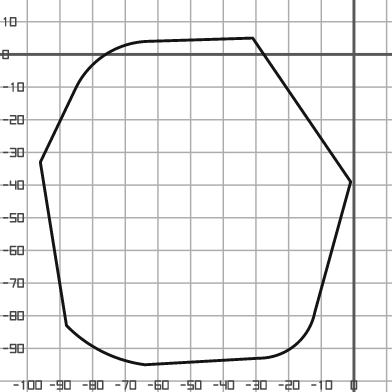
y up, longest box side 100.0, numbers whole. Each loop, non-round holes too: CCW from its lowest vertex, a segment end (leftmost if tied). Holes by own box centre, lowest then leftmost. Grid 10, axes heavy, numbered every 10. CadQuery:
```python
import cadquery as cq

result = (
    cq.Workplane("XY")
    .moveTo(-64.0, -95.0)
    .lineTo(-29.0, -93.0)
    .threePointArc((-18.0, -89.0), (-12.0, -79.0))
    .lineTo(-1.0, -39.0)
    .lineTo(-31.0, 5.0)
    .lineTo(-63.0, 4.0)
    .threePointArc((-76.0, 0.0), (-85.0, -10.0))
    .lineTo(-96.0, -33.0)
    .lineTo(-88.0, -83.0)
    .threePointArc((-77.0, -91.0), (-64.0, -95.0))
    .close()
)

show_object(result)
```